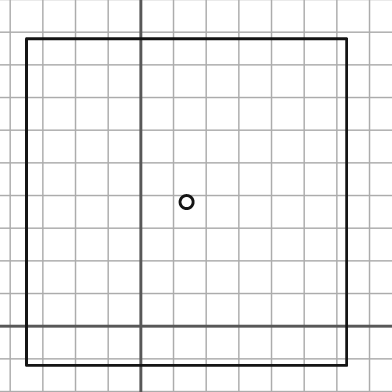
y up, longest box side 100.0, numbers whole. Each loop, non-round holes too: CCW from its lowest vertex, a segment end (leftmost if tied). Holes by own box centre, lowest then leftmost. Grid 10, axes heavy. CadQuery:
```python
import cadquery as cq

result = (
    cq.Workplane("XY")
    .moveTo(-35.0, -12.0)
    .lineTo(63.0, -12.0)
    .lineTo(63.0, 88.0)
    .lineTo(-35.0, 88.0)
    .close()
    .moveTo(14.0, 38.0)
    .circle(2.0)
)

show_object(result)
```